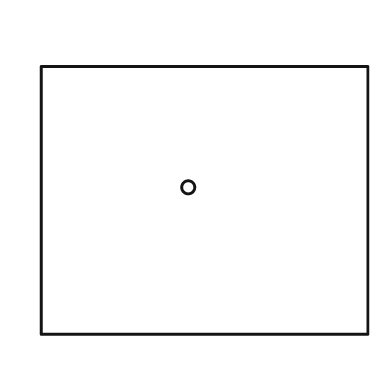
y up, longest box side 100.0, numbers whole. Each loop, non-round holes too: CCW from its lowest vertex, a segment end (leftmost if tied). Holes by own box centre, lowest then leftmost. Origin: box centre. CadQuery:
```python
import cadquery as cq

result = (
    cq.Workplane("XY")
    .moveTo(-50.0, -41.0)
    .lineTo(50.0, -41.0)
    .lineTo(50.0, 41.0)
    .lineTo(-50.0, 41.0)
    .close()
    .moveTo(-5.0, 4.0)
    .circle(2.0)
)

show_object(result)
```